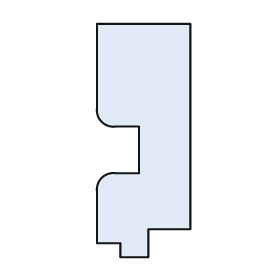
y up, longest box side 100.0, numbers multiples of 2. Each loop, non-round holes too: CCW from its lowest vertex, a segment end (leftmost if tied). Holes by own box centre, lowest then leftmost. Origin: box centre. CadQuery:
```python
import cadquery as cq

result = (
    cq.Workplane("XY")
    .moveTo(-10.0, -50.0)
    .lineTo(2.0, -50.0)
    .lineTo(2.0, -38.0)
    .lineTo(20.0, -38.0)
    .lineTo(20.0, 50.0)
    .lineTo(-20.0, 50.0)
    .lineTo(-20.0, 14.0)
    .threePointArc((-18.0, 8.0), (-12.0, 6.0))
    .lineTo(-2.0, 6.0)
    .lineTo(-2.0, -14.0)
    .lineTo(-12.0, -14.0)
    .threePointArc((-18.0, -16.0), (-20.0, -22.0))
    .lineTo(-20.0, -44.0)
    .lineTo(-10.0, -44.0)
    .close()
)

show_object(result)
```